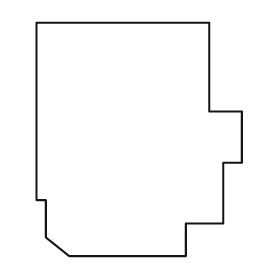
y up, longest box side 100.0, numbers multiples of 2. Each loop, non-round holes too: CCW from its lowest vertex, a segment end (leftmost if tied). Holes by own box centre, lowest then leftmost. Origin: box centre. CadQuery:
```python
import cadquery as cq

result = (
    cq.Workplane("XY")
    .moveTo(-30.0, -50.0)
    .lineTo(20.0, -50.0)
    .lineTo(20.0, -36.0)
    .lineTo(36.0, -36.0)
    .lineTo(36.0, -10.0)
    .lineTo(44.0, -10.0)
    .lineTo(44.0, 12.0)
    .lineTo(30.0, 12.0)
    .lineTo(30.0, 50.0)
    .lineTo(-44.0, 50.0)
    .lineTo(-44.0, -26.0)
    .lineTo(-40.0, -26.0)
    .lineTo(-40.0, -42.0)
    .close()
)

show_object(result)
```